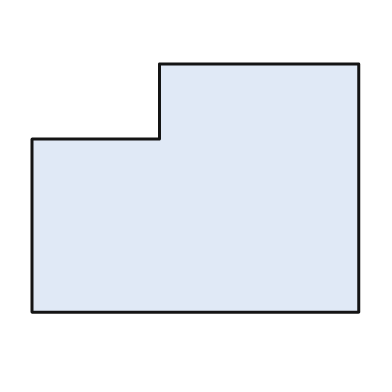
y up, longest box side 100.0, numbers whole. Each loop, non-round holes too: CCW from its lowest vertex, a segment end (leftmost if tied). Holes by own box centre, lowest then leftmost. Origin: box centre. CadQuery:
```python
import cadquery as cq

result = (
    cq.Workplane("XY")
    .moveTo(-50.0, -38.0)
    .lineTo(50.0, -38.0)
    .lineTo(50.0, 38.0)
    .lineTo(-11.0, 38.0)
    .lineTo(-11.0, 15.0)
    .lineTo(-50.0, 15.0)
    .close()
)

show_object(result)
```